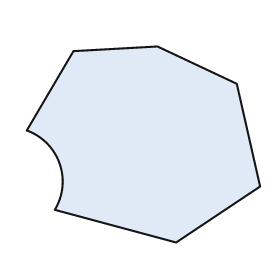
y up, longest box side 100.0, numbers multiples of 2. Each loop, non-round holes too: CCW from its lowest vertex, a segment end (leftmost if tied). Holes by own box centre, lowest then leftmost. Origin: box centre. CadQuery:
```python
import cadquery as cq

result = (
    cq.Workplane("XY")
    .moveTo(14.0, -42.0)
    .lineTo(50.0, -18.0)
    .lineTo(40.0, 26.0)
    .lineTo(6.0, 42.0)
    .lineTo(-30.0, 40.0)
    .lineTo(-50.0, 6.0)
    .threePointArc((-36.0, -8.0), (-38.0, -28.0))
    .close()
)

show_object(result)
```